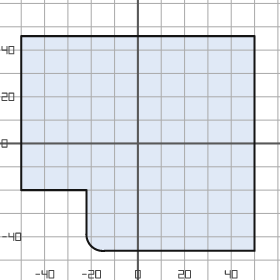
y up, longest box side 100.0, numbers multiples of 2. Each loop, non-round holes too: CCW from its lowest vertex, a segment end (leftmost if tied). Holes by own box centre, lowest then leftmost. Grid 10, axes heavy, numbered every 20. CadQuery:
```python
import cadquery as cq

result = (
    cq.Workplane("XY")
    .moveTo(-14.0, -46.0)
    .lineTo(50.0, -46.0)
    .lineTo(50.0, 46.0)
    .lineTo(-50.0, 46.0)
    .lineTo(-50.0, -20.0)
    .lineTo(-22.0, -20.0)
    .lineTo(-22.0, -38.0)
    .threePointArc((-20.0, -44.0), (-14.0, -46.0))
    .close()
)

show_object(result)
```